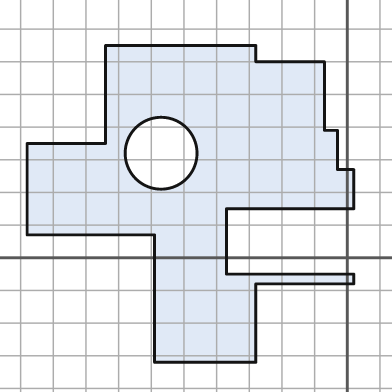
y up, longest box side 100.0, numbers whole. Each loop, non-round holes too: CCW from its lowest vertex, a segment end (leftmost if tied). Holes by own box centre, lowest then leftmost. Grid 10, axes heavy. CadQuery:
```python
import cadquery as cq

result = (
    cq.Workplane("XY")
    .moveTo(-59.0, -32.0)
    .lineTo(-28.0, -32.0)
    .lineTo(-28.0, -8.0)
    .lineTo(2.0, -8.0)
    .lineTo(2.0, -5.0)
    .lineTo(-37.0, -5.0)
    .lineTo(-37.0, 15.0)
    .lineTo(2.0, 15.0)
    .lineTo(2.0, 27.0)
    .lineTo(-3.0, 27.0)
    .lineTo(-3.0, 39.0)
    .lineTo(-7.0, 39.0)
    .lineTo(-7.0, 60.0)
    .lineTo(-28.0, 60.0)
    .lineTo(-28.0, 65.0)
    .lineTo(-74.0, 65.0)
    .lineTo(-74.0, 35.0)
    .lineTo(-98.0, 35.0)
    .lineTo(-98.0, 7.0)
    .lineTo(-59.0, 7.0)
    .close()
    .moveTo(-57.0, 32.0)
    .circle(11.0)
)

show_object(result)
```